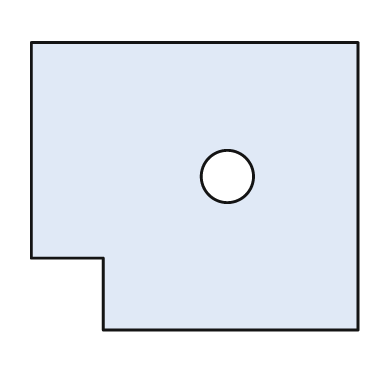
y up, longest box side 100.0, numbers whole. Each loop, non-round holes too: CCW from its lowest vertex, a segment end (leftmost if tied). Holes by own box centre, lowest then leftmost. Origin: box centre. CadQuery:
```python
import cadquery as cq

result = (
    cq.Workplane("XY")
    .moveTo(-28.0, -44.0)
    .lineTo(50.0, -44.0)
    .lineTo(50.0, 44.0)
    .lineTo(-50.0, 44.0)
    .lineTo(-50.0, -22.0)
    .lineTo(-28.0, -22.0)
    .close()
    .moveTo(10.0, 3.0)
    .circle(8.0)
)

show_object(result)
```